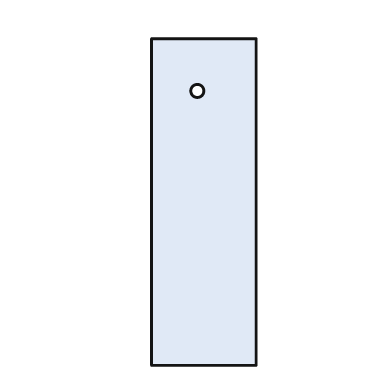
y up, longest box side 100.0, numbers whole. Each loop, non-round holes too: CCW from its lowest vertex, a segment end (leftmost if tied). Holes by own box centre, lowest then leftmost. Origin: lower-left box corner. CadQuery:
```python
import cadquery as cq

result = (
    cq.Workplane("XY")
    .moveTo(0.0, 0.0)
    .lineTo(32.0, 0.0)
    .lineTo(32.0, 100.0)
    .lineTo(0.0, 100.0)
    .close()
    .moveTo(14.0, 84.0)
    .circle(2.0)
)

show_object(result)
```